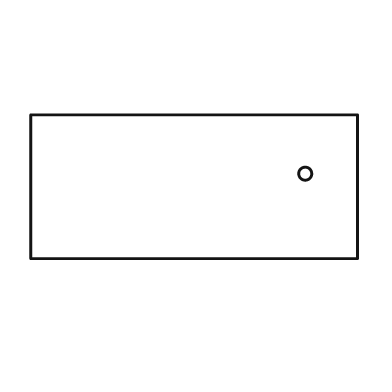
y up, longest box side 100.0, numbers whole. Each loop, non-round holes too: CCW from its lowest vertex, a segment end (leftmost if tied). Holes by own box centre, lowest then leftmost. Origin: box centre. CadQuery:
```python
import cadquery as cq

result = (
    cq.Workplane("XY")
    .moveTo(-50.0, -22.0)
    .lineTo(50.0, -22.0)
    .lineTo(50.0, 22.0)
    .lineTo(-50.0, 22.0)
    .close()
    .moveTo(34.0, 4.0)
    .circle(2.0)
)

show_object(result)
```